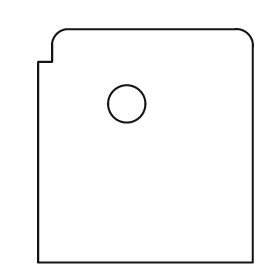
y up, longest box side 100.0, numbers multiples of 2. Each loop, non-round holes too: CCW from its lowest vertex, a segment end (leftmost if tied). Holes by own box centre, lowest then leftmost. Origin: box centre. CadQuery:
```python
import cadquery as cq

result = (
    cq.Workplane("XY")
    .moveTo(-46.0, -50.0)
    .lineTo(46.0, -50.0)
    .lineTo(46.0, 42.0)
    .threePointArc((44.0, 48.0), (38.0, 50.0))
    .lineTo(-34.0, 50.0)
    .threePointArc((-38.0, 48.0), (-40.0, 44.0))
    .lineTo(-40.0, 36.0)
    .lineTo(-46.0, 36.0)
    .close()
    .moveTo(-8.0, 18.0)
    .circle(8.0)
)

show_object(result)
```